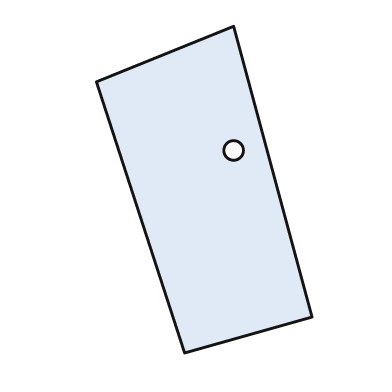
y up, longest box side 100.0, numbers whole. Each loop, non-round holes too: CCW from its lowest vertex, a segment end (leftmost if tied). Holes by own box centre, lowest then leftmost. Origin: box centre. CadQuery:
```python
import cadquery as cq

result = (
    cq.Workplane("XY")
    .moveTo(-6.0, -50.0)
    .lineTo(33.0, -39.0)
    .lineTo(9.0, 50.0)
    .lineTo(-33.0, 33.0)
    .close()
    .moveTo(9.0, 12.0)
    .circle(3.0)
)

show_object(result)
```